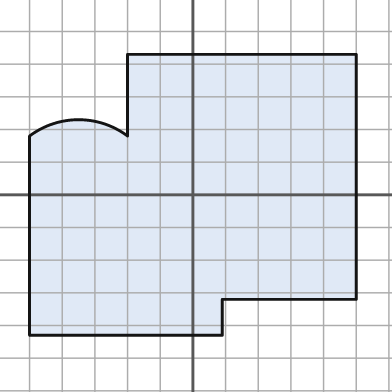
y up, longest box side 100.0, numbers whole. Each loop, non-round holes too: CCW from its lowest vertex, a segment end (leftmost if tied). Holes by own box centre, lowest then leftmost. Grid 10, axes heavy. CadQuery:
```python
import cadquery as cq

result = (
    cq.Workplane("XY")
    .moveTo(-50.0, -43.0)
    .lineTo(9.0, -43.0)
    .lineTo(9.0, -32.0)
    .lineTo(50.0, -32.0)
    .lineTo(50.0, 43.0)
    .lineTo(-20.0, 43.0)
    .lineTo(-20.0, 18.0)
    .threePointArc((-35.0, 23.0), (-50.0, 18.0))
    .close()
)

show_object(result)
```